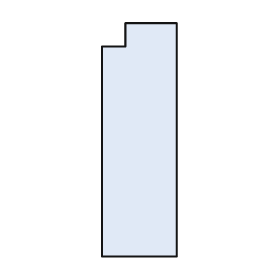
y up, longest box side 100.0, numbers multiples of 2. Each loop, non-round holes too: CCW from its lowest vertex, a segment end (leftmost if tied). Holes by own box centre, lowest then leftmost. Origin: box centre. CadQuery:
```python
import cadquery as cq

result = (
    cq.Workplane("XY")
    .moveTo(-16.0, -50.0)
    .lineTo(16.0, -50.0)
    .lineTo(16.0, 50.0)
    .lineTo(-6.0, 50.0)
    .lineTo(-6.0, 40.0)
    .lineTo(-16.0, 40.0)
    .close()
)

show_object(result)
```